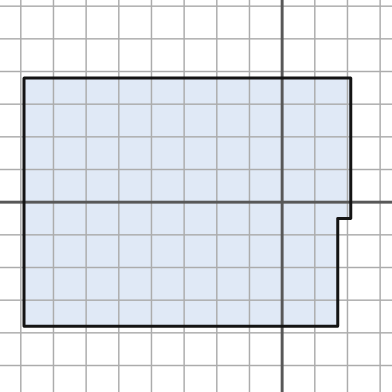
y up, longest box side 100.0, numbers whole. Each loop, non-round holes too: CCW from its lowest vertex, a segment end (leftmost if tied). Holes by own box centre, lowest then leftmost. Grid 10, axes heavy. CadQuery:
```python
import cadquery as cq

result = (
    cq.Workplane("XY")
    .moveTo(-79.0, -38.0)
    .lineTo(17.0, -38.0)
    .lineTo(17.0, -5.0)
    .lineTo(21.0, -5.0)
    .lineTo(21.0, 38.0)
    .lineTo(-79.0, 38.0)
    .close()
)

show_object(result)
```